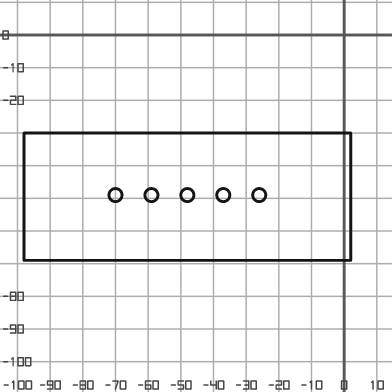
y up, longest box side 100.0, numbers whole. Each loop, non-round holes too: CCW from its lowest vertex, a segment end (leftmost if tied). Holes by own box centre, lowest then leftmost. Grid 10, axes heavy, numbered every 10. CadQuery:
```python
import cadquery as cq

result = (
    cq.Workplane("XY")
    .moveTo(-98.0, -69.0)
    .lineTo(2.0, -69.0)
    .lineTo(2.0, -30.0)
    .lineTo(-98.0, -30.0)
    .close()
    .moveTo(-70.0, -49.0)
    .circle(2.0)
    .moveTo(-59.0, -49.0)
    .circle(2.0)
    .moveTo(-48.0, -49.0)
    .circle(2.0)
    .moveTo(-37.0, -49.0)
    .circle(2.0)
    .moveTo(-26.0, -49.0)
    .circle(2.0)
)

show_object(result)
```